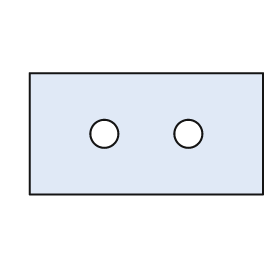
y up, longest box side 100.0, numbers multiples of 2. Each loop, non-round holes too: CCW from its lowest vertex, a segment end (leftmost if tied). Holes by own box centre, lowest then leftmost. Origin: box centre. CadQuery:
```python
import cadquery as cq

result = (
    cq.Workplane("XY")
    .moveTo(-50.0, -26.0)
    .lineTo(50.0, -26.0)
    .lineTo(50.0, 26.0)
    .lineTo(-50.0, 26.0)
    .close()
    .moveTo(-18.0, 0.0)
    .circle(6.0)
    .moveTo(18.0, 0.0)
    .circle(6.0)
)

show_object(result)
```